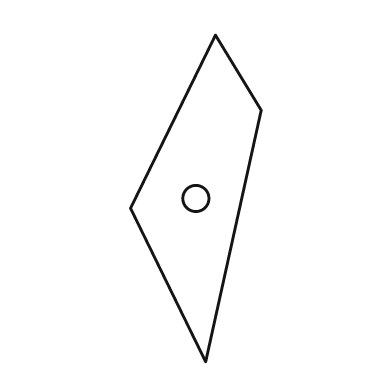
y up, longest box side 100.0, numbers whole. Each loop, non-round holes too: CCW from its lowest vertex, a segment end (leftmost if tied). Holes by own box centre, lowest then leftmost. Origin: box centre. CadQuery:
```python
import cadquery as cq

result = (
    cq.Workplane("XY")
    .moveTo(3.0, -50.0)
    .lineTo(20.0, 27.0)
    .lineTo(6.0, 50.0)
    .lineTo(-20.0, -3.0)
    .close()
    .moveTo(0.0, 0.0)
    .circle(4.0)
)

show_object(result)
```